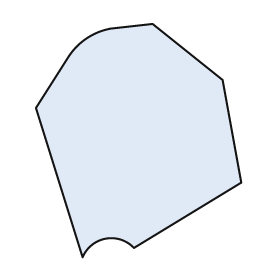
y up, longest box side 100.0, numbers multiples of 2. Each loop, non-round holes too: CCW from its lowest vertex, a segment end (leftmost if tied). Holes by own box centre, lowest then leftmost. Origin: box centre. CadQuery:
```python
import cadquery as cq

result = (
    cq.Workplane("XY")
    .moveTo(-24.0, -50.0)
    .threePointArc((-14.0, -42.0), (-2.0, -46.0))
    .lineTo(44.0, -18.0)
    .lineTo(36.0, 26.0)
    .lineTo(6.0, 50.0)
    .lineTo(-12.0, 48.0)
    .threePointArc((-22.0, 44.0), (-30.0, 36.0))
    .lineTo(-44.0, 14.0)
    .close()
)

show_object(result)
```